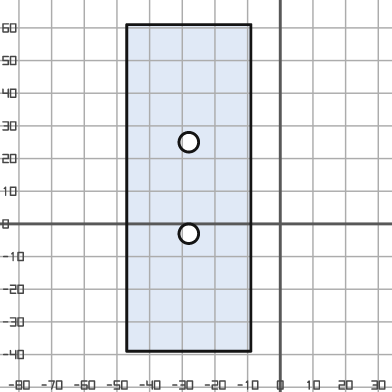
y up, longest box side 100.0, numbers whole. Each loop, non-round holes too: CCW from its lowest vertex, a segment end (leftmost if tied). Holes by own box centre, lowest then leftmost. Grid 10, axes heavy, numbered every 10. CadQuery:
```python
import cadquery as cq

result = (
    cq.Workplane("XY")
    .moveTo(-47.0, -39.0)
    .lineTo(-9.0, -39.0)
    .lineTo(-9.0, 61.0)
    .lineTo(-47.0, 61.0)
    .close()
    .moveTo(-28.0, -3.0)
    .circle(3.0)
    .moveTo(-28.0, 25.0)
    .circle(3.0)
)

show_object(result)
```